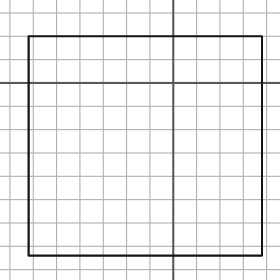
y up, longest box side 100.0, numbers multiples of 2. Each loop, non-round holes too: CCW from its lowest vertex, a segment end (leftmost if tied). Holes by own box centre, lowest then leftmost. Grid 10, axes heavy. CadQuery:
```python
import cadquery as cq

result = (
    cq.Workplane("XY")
    .moveTo(-62.0, -74.0)
    .lineTo(38.0, -74.0)
    .lineTo(38.0, 20.0)
    .lineTo(-62.0, 20.0)
    .close()
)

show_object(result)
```